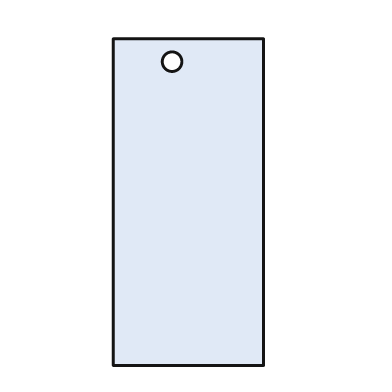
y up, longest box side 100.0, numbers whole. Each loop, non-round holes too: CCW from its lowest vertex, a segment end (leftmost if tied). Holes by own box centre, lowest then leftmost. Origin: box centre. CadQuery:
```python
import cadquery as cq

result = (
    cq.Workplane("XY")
    .moveTo(-23.0, -50.0)
    .lineTo(23.0, -50.0)
    .lineTo(23.0, 50.0)
    .lineTo(-23.0, 50.0)
    .close()
    .moveTo(-5.0, 43.0)
    .circle(3.0)
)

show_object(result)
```